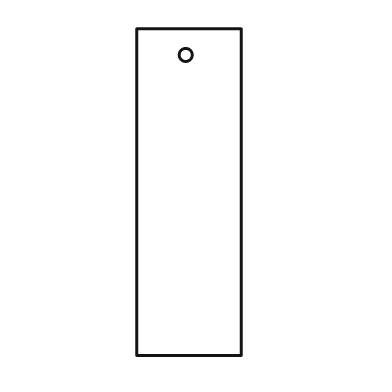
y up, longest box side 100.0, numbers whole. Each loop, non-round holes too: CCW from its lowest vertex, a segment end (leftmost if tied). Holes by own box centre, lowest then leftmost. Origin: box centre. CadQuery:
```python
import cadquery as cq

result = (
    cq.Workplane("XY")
    .moveTo(-16.0, -50.0)
    .lineTo(16.0, -50.0)
    .lineTo(16.0, 50.0)
    .lineTo(-16.0, 50.0)
    .close()
    .moveTo(-1.0, 42.0)
    .circle(2.0)
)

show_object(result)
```